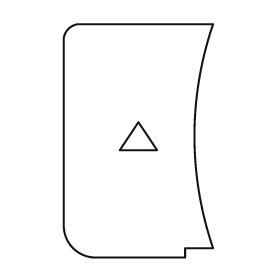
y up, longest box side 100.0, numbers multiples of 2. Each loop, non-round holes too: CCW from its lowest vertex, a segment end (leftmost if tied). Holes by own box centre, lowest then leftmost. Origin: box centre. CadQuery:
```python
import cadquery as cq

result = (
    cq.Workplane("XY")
    .moveTo(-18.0, -50.0)
    .lineTo(20.0, -50.0)
    .lineTo(20.0, -46.0)
    .lineTo(32.0, -46.0)
    .threePointArc((24.0, 2.0), (32.0, 50.0))
    .lineTo(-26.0, 50.0)
    .threePointArc((-30.0, 48.0), (-32.0, 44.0))
    .lineTo(-32.0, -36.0)
    .threePointArc((-28.0, -46.0), (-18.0, -50.0))
    .close()
    .moveTo(-8.0, -4.0)
    .lineTo(8.0, -4.0)
    .lineTo(0.0, 8.0)
    .close()
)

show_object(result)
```